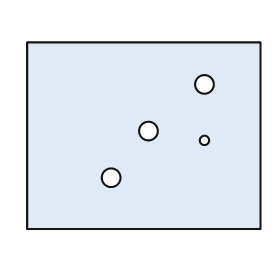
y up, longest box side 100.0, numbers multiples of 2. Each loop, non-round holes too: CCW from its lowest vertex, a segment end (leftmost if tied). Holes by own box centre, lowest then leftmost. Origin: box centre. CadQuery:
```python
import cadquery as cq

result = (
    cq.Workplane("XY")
    .moveTo(-50.0, -40.0)
    .lineTo(50.0, -40.0)
    .lineTo(50.0, 40.0)
    .lineTo(-50.0, 40.0)
    .close()
    .moveTo(-14.0, -18.0)
    .circle(4.0)
    .moveTo(26.0, -2.0)
    .circle(2.0)
    .moveTo(2.0, 2.0)
    .circle(4.0)
    .moveTo(26.0, 22.0)
    .circle(4.0)
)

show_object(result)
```